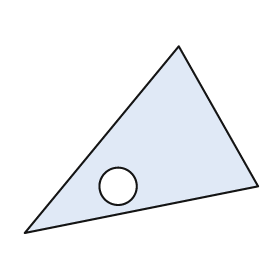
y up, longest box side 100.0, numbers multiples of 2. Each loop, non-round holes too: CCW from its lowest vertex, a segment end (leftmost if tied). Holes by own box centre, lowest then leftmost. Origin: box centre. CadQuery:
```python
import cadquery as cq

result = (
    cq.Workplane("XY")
    .moveTo(-50.0, -40.0)
    .lineTo(50.0, -20.0)
    .lineTo(16.0, 40.0)
    .close()
    .moveTo(-10.0, -20.0)
    .circle(8.0)
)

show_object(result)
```